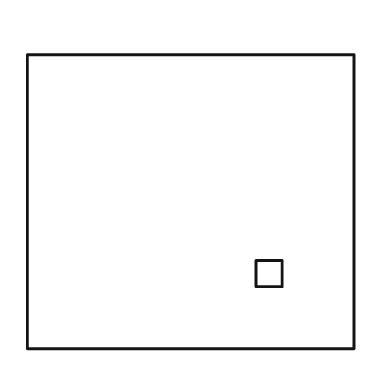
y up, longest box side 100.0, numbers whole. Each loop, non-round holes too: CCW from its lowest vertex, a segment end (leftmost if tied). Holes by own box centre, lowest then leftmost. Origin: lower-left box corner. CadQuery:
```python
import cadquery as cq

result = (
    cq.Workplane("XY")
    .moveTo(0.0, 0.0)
    .lineTo(100.0, 0.0)
    .lineTo(100.0, 90.0)
    .lineTo(0.0, 90.0)
    .close()
    .moveTo(70.0, 19.0)
    .lineTo(78.0, 19.0)
    .lineTo(78.0, 27.0)
    .lineTo(70.0, 27.0)
    .close()
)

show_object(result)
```